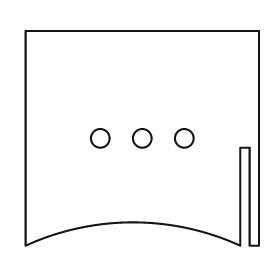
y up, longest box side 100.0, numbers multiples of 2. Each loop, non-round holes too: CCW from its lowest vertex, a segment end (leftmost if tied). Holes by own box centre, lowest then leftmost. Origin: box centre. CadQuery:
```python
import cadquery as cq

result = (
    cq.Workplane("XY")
    .moveTo(-50.0, -46.0)
    .threePointArc((-4.0, -36.0), (42.0, -46.0))
    .lineTo(42.0, -4.0)
    .lineTo(46.0, -4.0)
    .lineTo(46.0, -46.0)
    .lineTo(50.0, -46.0)
    .lineTo(50.0, 46.0)
    .lineTo(-50.0, 46.0)
    .close()
    .moveTo(-18.0, 0.0)
    .circle(4.0)
    .moveTo(0.0, 0.0)
    .circle(4.0)
    .moveTo(18.0, 0.0)
    .circle(4.0)
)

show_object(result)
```